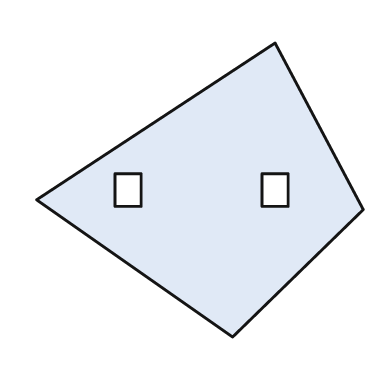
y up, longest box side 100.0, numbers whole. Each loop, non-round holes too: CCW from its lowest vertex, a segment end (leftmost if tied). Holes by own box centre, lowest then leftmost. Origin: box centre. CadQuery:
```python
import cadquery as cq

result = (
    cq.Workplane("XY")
    .moveTo(10.0, -45.0)
    .lineTo(50.0, -6.0)
    .lineTo(23.0, 45.0)
    .lineTo(-50.0, -3.0)
    .close()
    .moveTo(-26.0, -5.0)
    .lineTo(-18.0, -5.0)
    .lineTo(-18.0, 5.0)
    .lineTo(-26.0, 5.0)
    .close()
    .moveTo(19.0, -5.0)
    .lineTo(27.0, -5.0)
    .lineTo(27.0, 5.0)
    .lineTo(19.0, 5.0)
    .close()
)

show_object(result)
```